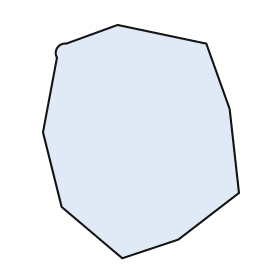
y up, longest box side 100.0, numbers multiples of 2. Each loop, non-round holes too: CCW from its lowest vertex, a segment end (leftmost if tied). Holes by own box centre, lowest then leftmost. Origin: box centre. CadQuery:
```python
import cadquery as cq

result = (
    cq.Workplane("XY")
    .moveTo(-8.0, -50.0)
    .lineTo(16.0, -42.0)
    .lineTo(42.0, -22.0)
    .lineTo(38.0, 14.0)
    .lineTo(28.0, 42.0)
    .lineTo(-10.0, 50.0)
    .lineTo(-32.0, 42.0)
    .threePointArc((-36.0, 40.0), (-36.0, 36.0))
    .lineTo(-42.0, 4.0)
    .lineTo(-34.0, -28.0)
    .close()
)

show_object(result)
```